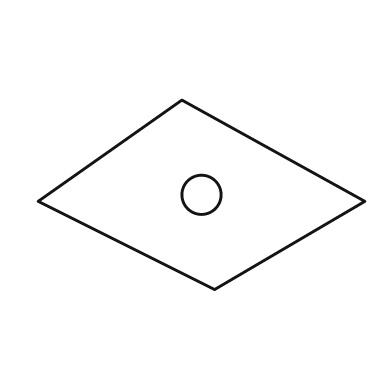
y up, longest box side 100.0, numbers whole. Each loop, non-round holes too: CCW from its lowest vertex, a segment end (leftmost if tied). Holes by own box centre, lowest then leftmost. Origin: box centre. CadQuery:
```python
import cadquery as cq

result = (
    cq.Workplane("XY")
    .moveTo(4.0, -29.0)
    .lineTo(50.0, -2.0)
    .lineTo(-6.0, 29.0)
    .lineTo(-50.0, -2.0)
    .close()
    .moveTo(0.0, 0.0)
    .circle(6.0)
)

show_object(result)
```